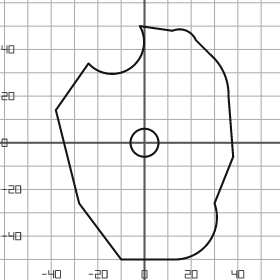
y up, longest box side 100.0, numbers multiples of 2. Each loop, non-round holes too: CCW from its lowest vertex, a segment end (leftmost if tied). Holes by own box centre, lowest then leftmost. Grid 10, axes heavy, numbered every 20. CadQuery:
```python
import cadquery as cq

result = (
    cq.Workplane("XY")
    .moveTo(-10.0, -50.0)
    .lineTo(14.0, -50.0)
    .threePointArc((28.0, -42.0), (30.0, -26.0))
    .lineTo(38.0, -6.0)
    .lineTo(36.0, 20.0)
    .threePointArc((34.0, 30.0), (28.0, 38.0))
    .lineTo(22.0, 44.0)
    .threePointArc((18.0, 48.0), (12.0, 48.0))
    .lineTo(-2.0, 50.0)
    .threePointArc((-6.0, 32.0), (-24.0, 34.0))
    .lineTo(-38.0, 14.0)
    .lineTo(-28.0, -26.0)
    .close()
    .moveTo(0.0, 0.0)
    .circle(6.0)
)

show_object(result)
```